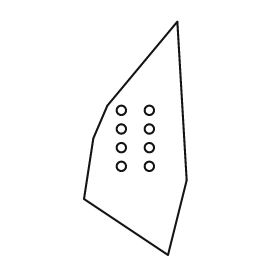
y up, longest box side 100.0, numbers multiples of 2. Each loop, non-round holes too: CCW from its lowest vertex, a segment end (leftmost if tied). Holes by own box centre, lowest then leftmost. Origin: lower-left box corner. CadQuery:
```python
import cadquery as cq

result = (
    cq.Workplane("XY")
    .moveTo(36.0, 0.0)
    .lineTo(44.0, 32.0)
    .lineTo(40.0, 100.0)
    .lineTo(10.0, 64.0)
    .lineTo(4.0, 50.0)
    .lineTo(0.0, 24.0)
    .close()
    .moveTo(16.0, 38.0)
    .circle(2.0)
    .moveTo(28.0, 38.0)
    .circle(2.0)
    .moveTo(16.0, 46.0)
    .circle(2.0)
    .moveTo(28.0, 46.0)
    .circle(2.0)
    .moveTo(16.0, 54.0)
    .circle(2.0)
    .moveTo(28.0, 54.0)
    .circle(2.0)
    .moveTo(16.0, 62.0)
    .circle(2.0)
    .moveTo(28.0, 62.0)
    .circle(2.0)
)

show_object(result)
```